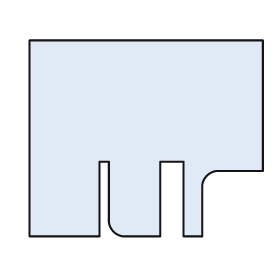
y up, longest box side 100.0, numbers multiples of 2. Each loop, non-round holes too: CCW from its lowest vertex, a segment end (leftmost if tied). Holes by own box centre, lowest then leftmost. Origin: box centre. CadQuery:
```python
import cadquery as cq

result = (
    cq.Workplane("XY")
    .moveTo(-50.0, -42.0)
    .lineTo(-20.0, -42.0)
    .lineTo(-20.0, -10.0)
    .lineTo(-16.0, -10.0)
    .lineTo(-16.0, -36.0)
    .threePointArc((-14.0, -40.0), (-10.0, -42.0))
    .lineTo(6.0, -42.0)
    .lineTo(6.0, -10.0)
    .lineTo(16.0, -10.0)
    .lineTo(16.0, -42.0)
    .lineTo(24.0, -42.0)
    .lineTo(24.0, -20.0)
    .threePointArc((26.0, -16.0), (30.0, -14.0))
    .lineTo(50.0, -14.0)
    .lineTo(50.0, 42.0)
    .lineTo(-50.0, 42.0)
    .close()
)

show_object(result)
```